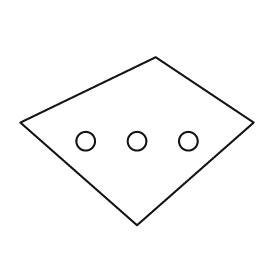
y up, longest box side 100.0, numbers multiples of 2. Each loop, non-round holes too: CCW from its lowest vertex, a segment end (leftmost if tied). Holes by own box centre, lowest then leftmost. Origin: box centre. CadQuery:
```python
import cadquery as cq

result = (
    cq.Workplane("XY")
    .moveTo(0.0, -36.0)
    .lineTo(50.0, 8.0)
    .lineTo(8.0, 36.0)
    .lineTo(-50.0, 8.0)
    .close()
    .moveTo(-22.0, 0.0)
    .circle(4.0)
    .moveTo(0.0, 0.0)
    .circle(4.0)
    .moveTo(22.0, 0.0)
    .circle(4.0)
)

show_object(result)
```